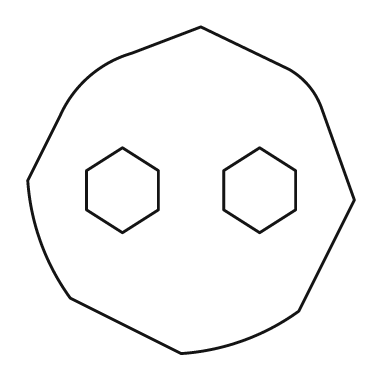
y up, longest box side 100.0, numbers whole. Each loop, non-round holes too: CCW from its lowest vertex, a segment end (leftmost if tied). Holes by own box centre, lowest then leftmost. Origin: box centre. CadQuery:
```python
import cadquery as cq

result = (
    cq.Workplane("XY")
    .moveTo(-3.0, -50.0)
    .threePointArc((16.0, -46.0), (33.0, -37.0))
    .lineTo(50.0, -3.0)
    .lineTo(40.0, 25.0)
    .threePointArc((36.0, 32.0), (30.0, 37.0))
    .lineTo(3.0, 50.0)
    .lineTo(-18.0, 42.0)
    .threePointArc((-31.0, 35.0), (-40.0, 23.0))
    .lineTo(-50.0, 3.0)
    .threePointArc((-46.0, -16.0), (-37.0, -33.0))
    .close()
    .moveTo(-21.0, -13.0)
    .lineTo(-10.0, -6.0)
    .lineTo(-10.0, 6.0)
    .lineTo(-21.0, 13.0)
    .lineTo(-32.0, 6.0)
    .lineTo(-32.0, -6.0)
    .close()
    .moveTo(21.0, -13.0)
    .lineTo(32.0, -6.0)
    .lineTo(32.0, 6.0)
    .lineTo(21.0, 13.0)
    .lineTo(10.0, 6.0)
    .lineTo(10.0, -6.0)
    .close()
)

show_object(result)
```